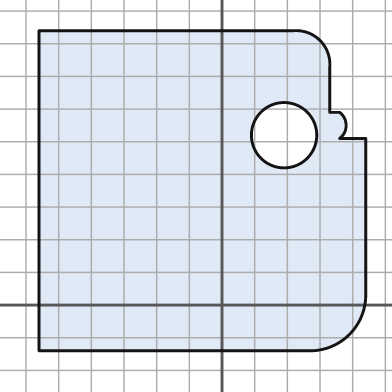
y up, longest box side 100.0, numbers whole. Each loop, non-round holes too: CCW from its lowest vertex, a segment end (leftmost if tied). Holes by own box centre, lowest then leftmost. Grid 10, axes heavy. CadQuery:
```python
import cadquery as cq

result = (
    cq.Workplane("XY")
    .moveTo(-56.0, -14.0)
    .lineTo(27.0, -14.0)
    .threePointArc((39.0, -9.0), (44.0, 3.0))
    .lineTo(44.0, 51.0)
    .lineTo(36.0, 51.0)
    .threePointArc((38.0, 55.0), (36.0, 59.0))
    .lineTo(33.0, 59.0)
    .lineTo(33.0, 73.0)
    .threePointArc((30.0, 81.0), (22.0, 84.0))
    .lineTo(-56.0, 84.0)
    .close()
    .moveTo(19.0, 52.0)
    .circle(10.0)
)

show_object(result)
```